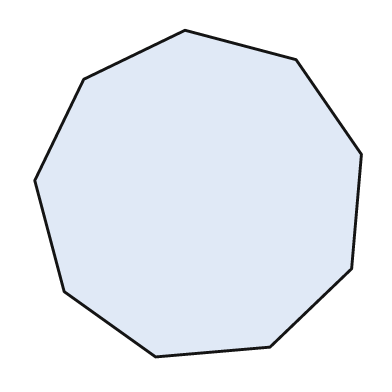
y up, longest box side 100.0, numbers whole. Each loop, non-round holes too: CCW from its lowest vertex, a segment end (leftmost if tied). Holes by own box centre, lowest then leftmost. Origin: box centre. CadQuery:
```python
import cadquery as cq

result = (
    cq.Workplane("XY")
    .moveTo(-13.0, -50.0)
    .lineTo(22.0, -47.0)
    .lineTo(47.0, -23.0)
    .lineTo(50.0, 12.0)
    .lineTo(30.0, 41.0)
    .lineTo(-4.0, 50.0)
    .lineTo(-35.0, 35.0)
    .lineTo(-50.0, 4.0)
    .lineTo(-41.0, -30.0)
    .close()
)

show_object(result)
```